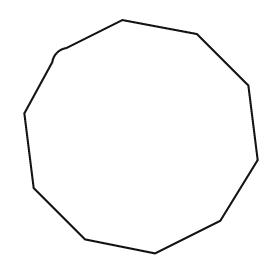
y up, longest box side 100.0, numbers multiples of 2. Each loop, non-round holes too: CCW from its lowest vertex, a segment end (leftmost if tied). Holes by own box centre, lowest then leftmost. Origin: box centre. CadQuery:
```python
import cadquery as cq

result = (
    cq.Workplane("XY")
    .moveTo(6.0, -50.0)
    .lineTo(34.0, -36.0)
    .lineTo(50.0, -10.0)
    .lineTo(46.0, 22.0)
    .lineTo(24.0, 44.0)
    .lineTo(-8.0, 50.0)
    .lineTo(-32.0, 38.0)
    .threePointArc((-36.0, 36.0), (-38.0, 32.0))
    .lineTo(-50.0, 10.0)
    .lineTo(-46.0, -22.0)
    .lineTo(-24.0, -44.0)
    .close()
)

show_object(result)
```